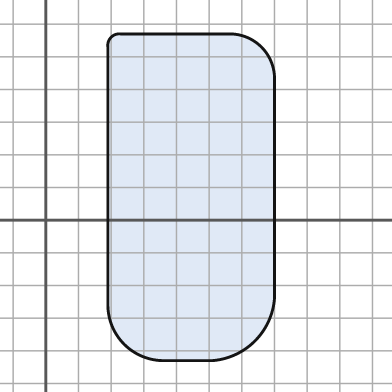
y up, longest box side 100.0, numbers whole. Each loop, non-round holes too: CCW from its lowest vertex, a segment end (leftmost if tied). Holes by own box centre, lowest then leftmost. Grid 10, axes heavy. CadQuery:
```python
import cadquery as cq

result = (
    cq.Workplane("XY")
    .moveTo(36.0, -43.0)
    .lineTo(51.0, -43.0)
    .threePointArc((64.0, -37.0), (70.0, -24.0))
    .lineTo(70.0, 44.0)
    .threePointArc((66.0, 53.0), (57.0, 57.0))
    .lineTo(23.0, 57.0)
    .threePointArc((20.0, 56.0), (19.0, 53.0))
    .lineTo(19.0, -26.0)
    .threePointArc((24.0, -38.0), (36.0, -43.0))
    .close()
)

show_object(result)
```